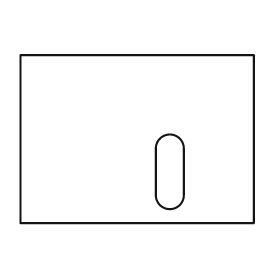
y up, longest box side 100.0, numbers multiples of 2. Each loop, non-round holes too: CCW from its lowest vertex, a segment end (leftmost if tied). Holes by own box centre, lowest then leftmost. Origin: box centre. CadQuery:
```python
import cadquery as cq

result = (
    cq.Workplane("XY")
    .moveTo(-50.0, -36.0)
    .lineTo(50.0, -36.0)
    .lineTo(50.0, 36.0)
    .lineTo(-50.0, 36.0)
    .close()
    .moveTo(8.0, -24.0)
    .threePointArc((14.0, -30.0), (20.0, -24.0))
    .lineTo(20.0, -4.0)
    .threePointArc((14.0, 2.0), (8.0, -4.0))
    .close()
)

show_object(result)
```